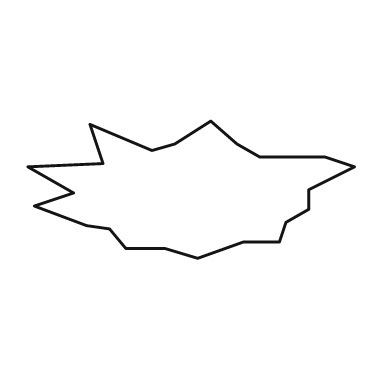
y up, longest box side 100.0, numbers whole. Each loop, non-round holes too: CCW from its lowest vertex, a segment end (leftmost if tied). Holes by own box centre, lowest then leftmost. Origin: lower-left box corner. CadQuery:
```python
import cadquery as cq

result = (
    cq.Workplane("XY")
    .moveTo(52.0, 0.0)
    .lineTo(66.0, 5.0)
    .lineTo(77.0, 5.0)
    .lineTo(79.0, 11.0)
    .lineTo(86.0, 15.0)
    .lineTo(86.0, 21.0)
    .lineTo(100.0, 28.0)
    .lineTo(91.0, 31.0)
    .lineTo(71.0, 31.0)
    .lineTo(64.0, 35.0)
    .lineTo(56.0, 42.0)
    .lineTo(45.0, 35.0)
    .lineTo(38.0, 33.0)
    .lineTo(19.0, 41.0)
    .lineTo(23.0, 29.0)
    .lineTo(0.0, 28.0)
    .lineTo(14.0, 20.0)
    .lineTo(2.0, 16.0)
    .lineTo(18.0, 10.0)
    .lineTo(25.0, 9.0)
    .lineTo(30.0, 3.0)
    .lineTo(42.0, 3.0)
    .close()
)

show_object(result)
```